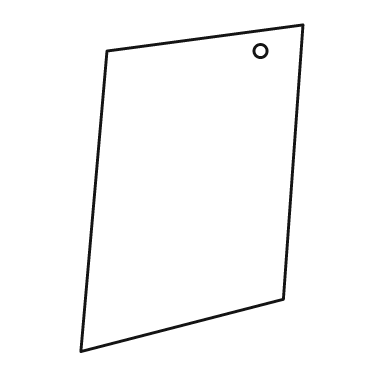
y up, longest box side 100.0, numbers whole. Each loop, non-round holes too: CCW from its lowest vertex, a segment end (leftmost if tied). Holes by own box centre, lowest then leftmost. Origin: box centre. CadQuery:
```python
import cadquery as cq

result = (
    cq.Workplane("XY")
    .moveTo(-34.0, -50.0)
    .lineTo(28.0, -34.0)
    .lineTo(34.0, 50.0)
    .lineTo(-26.0, 42.0)
    .close()
    .moveTo(21.0, 42.0)
    .circle(2.0)
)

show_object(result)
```